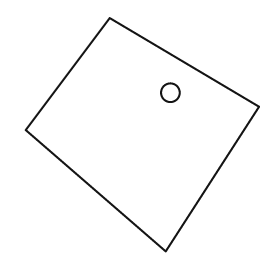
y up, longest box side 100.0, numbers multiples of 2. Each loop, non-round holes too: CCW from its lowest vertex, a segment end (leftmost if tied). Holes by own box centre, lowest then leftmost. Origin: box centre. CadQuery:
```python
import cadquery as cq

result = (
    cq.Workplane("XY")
    .moveTo(10.0, -50.0)
    .lineTo(50.0, 12.0)
    .lineTo(-14.0, 50.0)
    .lineTo(-50.0, 2.0)
    .close()
    .moveTo(12.0, 18.0)
    .circle(4.0)
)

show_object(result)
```